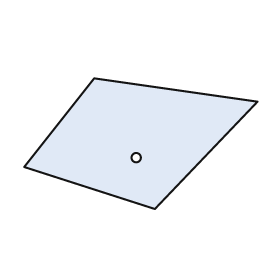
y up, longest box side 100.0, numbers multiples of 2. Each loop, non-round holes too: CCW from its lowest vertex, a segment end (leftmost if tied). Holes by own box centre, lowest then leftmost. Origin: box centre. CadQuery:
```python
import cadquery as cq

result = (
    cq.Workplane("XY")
    .moveTo(6.0, -28.0)
    .lineTo(50.0, 18.0)
    .lineTo(-20.0, 28.0)
    .lineTo(-50.0, -10.0)
    .close()
    .moveTo(-2.0, -6.0)
    .circle(2.0)
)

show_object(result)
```